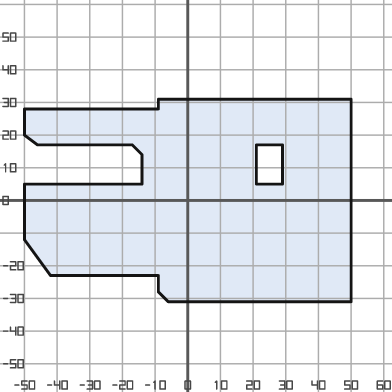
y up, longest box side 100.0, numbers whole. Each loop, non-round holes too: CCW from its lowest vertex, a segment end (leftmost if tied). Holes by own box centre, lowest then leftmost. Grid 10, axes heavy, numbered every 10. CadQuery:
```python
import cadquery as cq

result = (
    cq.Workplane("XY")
    .moveTo(-6.0, -31.0)
    .lineTo(50.0, -31.0)
    .lineTo(50.0, 31.0)
    .lineTo(-9.0, 31.0)
    .lineTo(-9.0, 28.0)
    .lineTo(-50.0, 28.0)
    .lineTo(-50.0, 20.0)
    .lineTo(-46.0, 17.0)
    .lineTo(-17.0, 17.0)
    .lineTo(-14.0, 14.0)
    .lineTo(-14.0, 5.0)
    .lineTo(-50.0, 5.0)
    .lineTo(-50.0, -12.0)
    .lineTo(-42.0, -23.0)
    .lineTo(-9.0, -23.0)
    .lineTo(-9.0, -28.0)
    .close()
    .moveTo(21.0, 5.0)
    .lineTo(29.0, 5.0)
    .lineTo(29.0, 17.0)
    .lineTo(21.0, 17.0)
    .close()
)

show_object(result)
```